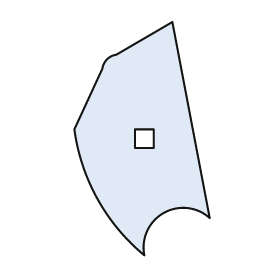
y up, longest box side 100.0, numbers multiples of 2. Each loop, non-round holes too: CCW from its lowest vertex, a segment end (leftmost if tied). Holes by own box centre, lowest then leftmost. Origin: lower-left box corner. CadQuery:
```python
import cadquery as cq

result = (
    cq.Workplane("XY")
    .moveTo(30.0, 0.0)
    .threePointArc((38.0, 18.0), (58.0, 16.0))
    .lineTo(42.0, 100.0)
    .lineTo(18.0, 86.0)
    .threePointArc((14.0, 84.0), (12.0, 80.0))
    .lineTo(0.0, 54.0)
    .threePointArc((10.0, 24.0), (30.0, 0.0))
    .close()
    .moveTo(26.0, 46.0)
    .lineTo(34.0, 46.0)
    .lineTo(34.0, 54.0)
    .lineTo(26.0, 54.0)
    .close()
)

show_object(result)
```